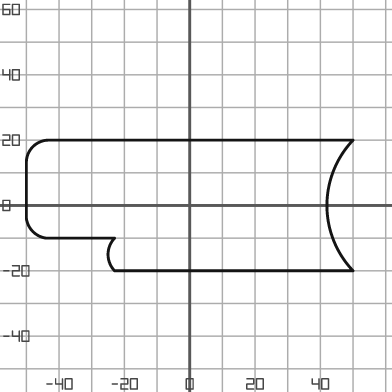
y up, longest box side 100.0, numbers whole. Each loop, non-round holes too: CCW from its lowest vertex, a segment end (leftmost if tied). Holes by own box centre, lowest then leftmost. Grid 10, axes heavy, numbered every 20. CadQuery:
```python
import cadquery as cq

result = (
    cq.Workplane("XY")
    .moveTo(-23.0, -20.0)
    .lineTo(50.0, -20.0)
    .threePointArc((42.0, 0.0), (50.0, 20.0))
    .lineTo(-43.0, 20.0)
    .threePointArc((-48.0, 18.0), (-50.0, 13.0))
    .lineTo(-50.0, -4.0)
    .threePointArc((-48.0, -8.0), (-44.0, -10.0))
    .lineTo(-23.0, -10.0)
    .threePointArc((-25.0, -15.0), (-23.0, -20.0))
    .close()
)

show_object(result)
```